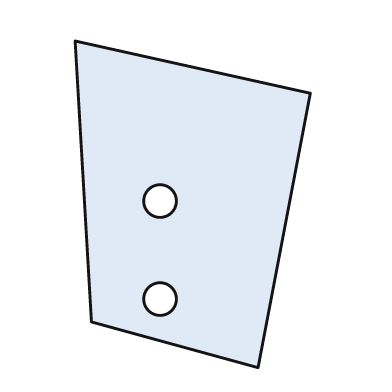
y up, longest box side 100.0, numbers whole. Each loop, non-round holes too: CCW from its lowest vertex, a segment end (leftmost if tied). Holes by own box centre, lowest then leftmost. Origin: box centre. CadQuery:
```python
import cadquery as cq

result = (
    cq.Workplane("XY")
    .moveTo(20.0, -50.0)
    .lineTo(36.0, 34.0)
    .lineTo(-36.0, 50.0)
    .lineTo(-31.0, -36.0)
    .close()
    .moveTo(-10.0, -29.0)
    .circle(5.0)
    .moveTo(-10.0, 1.0)
    .circle(5.0)
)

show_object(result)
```